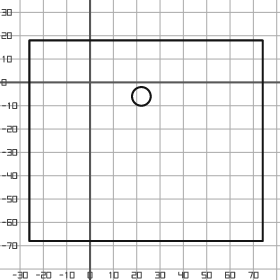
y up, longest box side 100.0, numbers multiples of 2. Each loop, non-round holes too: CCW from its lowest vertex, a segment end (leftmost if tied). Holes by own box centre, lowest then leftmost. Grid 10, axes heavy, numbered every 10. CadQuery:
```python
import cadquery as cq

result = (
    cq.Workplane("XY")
    .moveTo(-26.0, -68.0)
    .lineTo(74.0, -68.0)
    .lineTo(74.0, 18.0)
    .lineTo(-26.0, 18.0)
    .close()
    .moveTo(22.0, -6.0)
    .circle(4.0)
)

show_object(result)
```